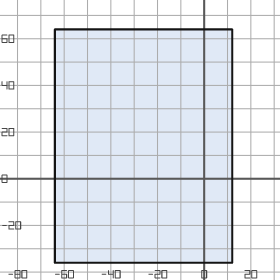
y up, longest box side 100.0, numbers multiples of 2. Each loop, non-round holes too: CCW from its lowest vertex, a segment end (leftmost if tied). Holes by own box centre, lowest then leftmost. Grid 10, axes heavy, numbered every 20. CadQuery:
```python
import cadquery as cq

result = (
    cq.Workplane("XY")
    .moveTo(-64.0, -36.0)
    .lineTo(12.0, -36.0)
    .lineTo(12.0, 64.0)
    .lineTo(-64.0, 64.0)
    .close()
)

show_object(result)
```